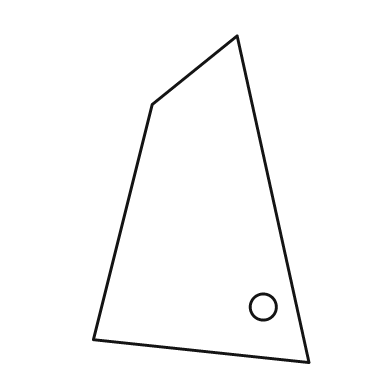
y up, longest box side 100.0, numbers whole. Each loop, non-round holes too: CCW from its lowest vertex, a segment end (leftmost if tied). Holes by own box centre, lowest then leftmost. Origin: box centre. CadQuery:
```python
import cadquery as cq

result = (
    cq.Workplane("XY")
    .moveTo(33.0, -50.0)
    .lineTo(11.0, 50.0)
    .lineTo(-15.0, 29.0)
    .lineTo(-33.0, -43.0)
    .close()
    .moveTo(19.0, -33.0)
    .circle(4.0)
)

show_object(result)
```